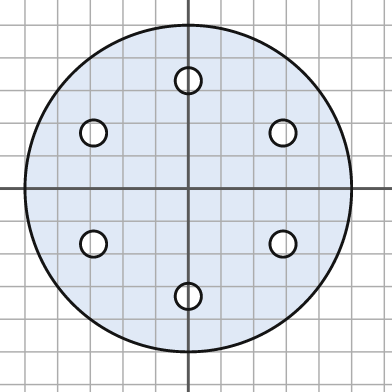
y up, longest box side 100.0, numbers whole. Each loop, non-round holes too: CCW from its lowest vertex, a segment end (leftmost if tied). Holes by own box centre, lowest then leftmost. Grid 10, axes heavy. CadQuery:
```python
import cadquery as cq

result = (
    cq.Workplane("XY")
    .moveTo(0.0, 0.0)
    .circle(50.0)
    .moveTo(0.0, -33.0)
    .circle(4.0)
    .moveTo(-29.0, -17.0)
    .circle(4.0)
    .moveTo(29.0, -17.0)
    .circle(4.0)
    .moveTo(-29.0, 17.0)
    .circle(4.0)
    .moveTo(29.0, 17.0)
    .circle(4.0)
    .moveTo(0.0, 33.0)
    .circle(4.0)
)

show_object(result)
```